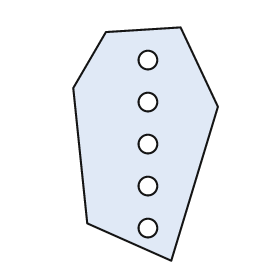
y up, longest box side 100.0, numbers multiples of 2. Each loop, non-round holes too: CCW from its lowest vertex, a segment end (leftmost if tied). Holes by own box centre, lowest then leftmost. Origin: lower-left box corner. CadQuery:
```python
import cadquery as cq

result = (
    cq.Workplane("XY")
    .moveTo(42.0, 0.0)
    .lineTo(62.0, 66.0)
    .lineTo(46.0, 100.0)
    .lineTo(14.0, 98.0)
    .lineTo(0.0, 74.0)
    .lineTo(6.0, 16.0)
    .close()
    .moveTo(32.0, 14.0)
    .circle(4.0)
    .moveTo(32.0, 32.0)
    .circle(4.0)
    .moveTo(32.0, 50.0)
    .circle(4.0)
    .moveTo(32.0, 68.0)
    .circle(4.0)
    .moveTo(32.0, 86.0)
    .circle(4.0)
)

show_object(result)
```